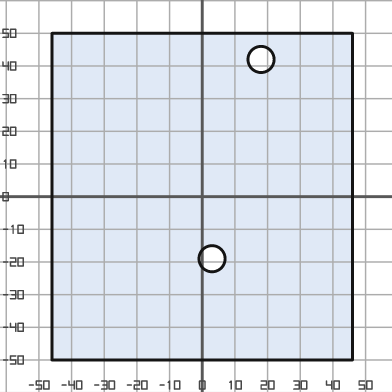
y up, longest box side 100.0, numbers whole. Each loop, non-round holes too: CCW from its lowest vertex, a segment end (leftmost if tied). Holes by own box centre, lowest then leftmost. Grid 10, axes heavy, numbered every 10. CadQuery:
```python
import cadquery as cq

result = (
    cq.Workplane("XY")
    .moveTo(-46.0, -50.0)
    .lineTo(46.0, -50.0)
    .lineTo(46.0, 50.0)
    .lineTo(-46.0, 50.0)
    .close()
    .moveTo(3.0, -19.0)
    .circle(4.0)
    .moveTo(18.0, 42.0)
    .circle(4.0)
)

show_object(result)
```